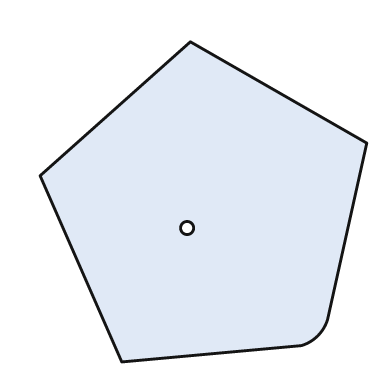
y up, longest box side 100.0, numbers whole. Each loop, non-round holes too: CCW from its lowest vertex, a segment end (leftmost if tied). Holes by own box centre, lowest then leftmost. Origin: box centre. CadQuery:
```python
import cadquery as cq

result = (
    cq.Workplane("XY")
    .moveTo(-25.0, -49.0)
    .lineTo(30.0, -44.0)
    .threePointArc((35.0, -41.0), (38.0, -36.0))
    .lineTo(50.0, 18.0)
    .lineTo(-4.0, 49.0)
    .lineTo(-50.0, 8.0)
    .close()
    .moveTo(-5.0, -8.0)
    .circle(2.0)
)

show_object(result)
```